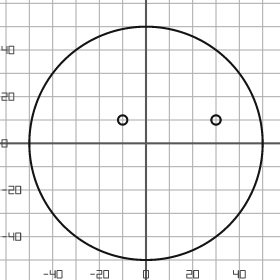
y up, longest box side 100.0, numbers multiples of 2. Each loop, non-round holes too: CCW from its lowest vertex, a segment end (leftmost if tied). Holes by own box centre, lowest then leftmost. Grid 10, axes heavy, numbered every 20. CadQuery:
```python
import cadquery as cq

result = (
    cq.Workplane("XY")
    .moveTo(0.0, 0.0)
    .circle(50.0)
    .moveTo(-10.0, 10.0)
    .circle(2.0)
    .moveTo(30.0, 10.0)
    .circle(2.0)
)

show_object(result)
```